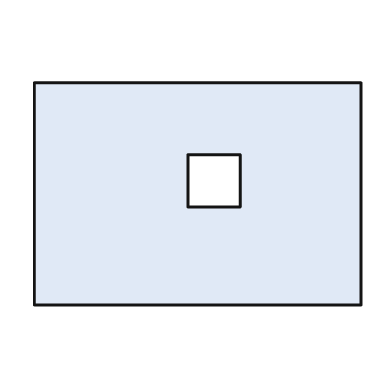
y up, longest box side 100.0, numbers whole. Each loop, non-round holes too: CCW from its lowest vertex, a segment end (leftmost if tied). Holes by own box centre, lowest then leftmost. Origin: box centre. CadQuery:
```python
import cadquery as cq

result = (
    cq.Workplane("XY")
    .moveTo(-50.0, -34.0)
    .lineTo(50.0, -34.0)
    .lineTo(50.0, 34.0)
    .lineTo(-50.0, 34.0)
    .close()
    .moveTo(-3.0, -4.0)
    .lineTo(13.0, -4.0)
    .lineTo(13.0, 12.0)
    .lineTo(-3.0, 12.0)
    .close()
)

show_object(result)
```